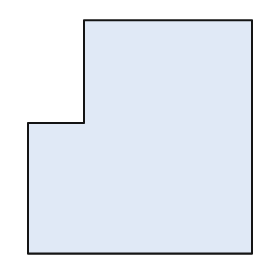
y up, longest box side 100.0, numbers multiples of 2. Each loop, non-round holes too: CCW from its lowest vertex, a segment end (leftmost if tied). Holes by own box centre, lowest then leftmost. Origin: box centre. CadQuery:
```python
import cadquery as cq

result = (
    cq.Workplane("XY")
    .moveTo(-48.0, -50.0)
    .lineTo(48.0, -50.0)
    .lineTo(48.0, 50.0)
    .lineTo(-24.0, 50.0)
    .lineTo(-24.0, 6.0)
    .lineTo(-48.0, 6.0)
    .close()
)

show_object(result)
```